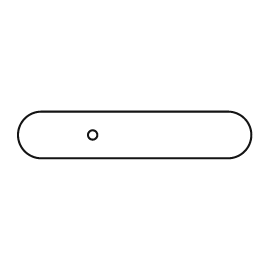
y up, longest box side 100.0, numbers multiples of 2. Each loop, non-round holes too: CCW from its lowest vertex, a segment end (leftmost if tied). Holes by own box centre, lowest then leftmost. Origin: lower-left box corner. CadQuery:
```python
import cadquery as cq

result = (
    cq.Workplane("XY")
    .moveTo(10.0, 0.0)
    .lineTo(90.0, 0.0)
    .threePointArc((100.0, 10.0), (90.0, 20.0))
    .lineTo(10.0, 20.0)
    .threePointArc((0.0, 10.0), (10.0, 0.0))
    .close()
    .moveTo(32.0, 10.0)
    .circle(2.0)
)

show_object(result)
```